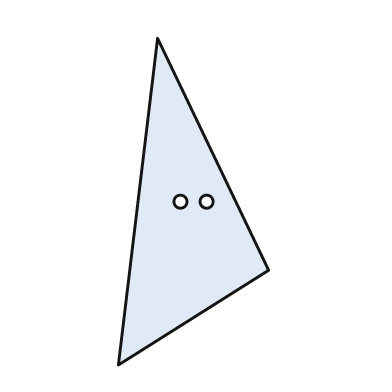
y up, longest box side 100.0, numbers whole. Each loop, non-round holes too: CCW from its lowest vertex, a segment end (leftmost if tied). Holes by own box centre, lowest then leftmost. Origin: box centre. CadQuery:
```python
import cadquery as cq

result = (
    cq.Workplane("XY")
    .moveTo(-23.0, -50.0)
    .lineTo(23.0, -21.0)
    .lineTo(-11.0, 50.0)
    .close()
    .moveTo(-4.0, 0.0)
    .circle(2.0)
    .moveTo(4.0, 0.0)
    .circle(2.0)
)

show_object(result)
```